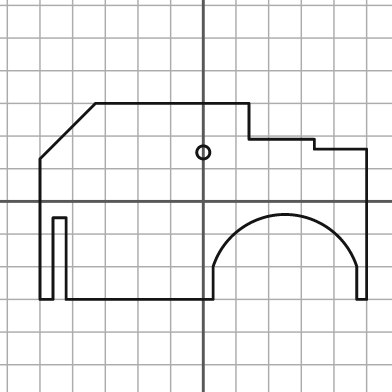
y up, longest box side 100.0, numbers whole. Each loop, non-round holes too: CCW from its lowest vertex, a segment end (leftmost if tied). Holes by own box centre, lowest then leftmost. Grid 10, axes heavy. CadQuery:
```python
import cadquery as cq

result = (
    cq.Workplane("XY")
    .moveTo(-50.0, -30.0)
    .lineTo(-46.0, -30.0)
    .lineTo(-46.0, -5.0)
    .lineTo(-42.0, -5.0)
    .lineTo(-42.0, -30.0)
    .lineTo(3.0, -30.0)
    .lineTo(3.0, -20.0)
    .threePointArc((25.0, -4.0), (47.0, -20.0))
    .lineTo(47.0, -30.0)
    .lineTo(50.0, -30.0)
    .lineTo(50.0, 16.0)
    .lineTo(34.0, 16.0)
    .lineTo(34.0, 19.0)
    .lineTo(14.0, 19.0)
    .lineTo(14.0, 30.0)
    .lineTo(-33.0, 30.0)
    .lineTo(-50.0, 13.0)
    .close()
    .moveTo(0.0, 15.0)
    .circle(2.0)
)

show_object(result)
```